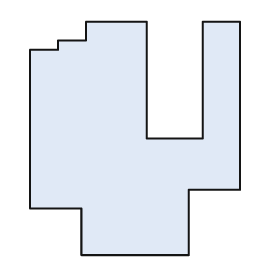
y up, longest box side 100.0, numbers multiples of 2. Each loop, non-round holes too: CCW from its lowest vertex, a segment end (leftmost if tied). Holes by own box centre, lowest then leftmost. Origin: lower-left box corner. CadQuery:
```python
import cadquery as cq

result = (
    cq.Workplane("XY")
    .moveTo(22.0, 0.0)
    .lineTo(68.0, 0.0)
    .lineTo(68.0, 28.0)
    .lineTo(90.0, 28.0)
    .lineTo(90.0, 100.0)
    .lineTo(74.0, 100.0)
    .lineTo(74.0, 50.0)
    .lineTo(50.0, 50.0)
    .lineTo(50.0, 100.0)
    .lineTo(24.0, 100.0)
    .lineTo(24.0, 92.0)
    .lineTo(12.0, 92.0)
    .lineTo(12.0, 88.0)
    .lineTo(0.0, 88.0)
    .lineTo(0.0, 20.0)
    .lineTo(22.0, 20.0)
    .close()
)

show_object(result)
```